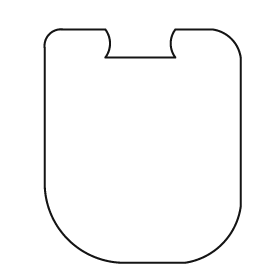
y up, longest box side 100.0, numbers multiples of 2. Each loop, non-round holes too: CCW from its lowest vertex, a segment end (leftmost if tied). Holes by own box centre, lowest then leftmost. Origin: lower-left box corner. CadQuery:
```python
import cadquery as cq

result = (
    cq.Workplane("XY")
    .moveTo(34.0, 0.0)
    .lineTo(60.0, 0.0)
    .threePointArc((76.0, 8.0), (84.0, 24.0))
    .lineTo(84.0, 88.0)
    .threePointArc((80.0, 96.0), (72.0, 100.0))
    .lineTo(56.0, 100.0)
    .threePointArc((54.0, 94.0), (56.0, 88.0))
    .lineTo(26.0, 88.0)
    .threePointArc((28.0, 94.0), (26.0, 100.0))
    .lineTo(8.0, 100.0)
    .threePointArc((2.0, 98.0), (0.0, 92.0))
    .lineTo(0.0, 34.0)
    .threePointArc((10.0, 10.0), (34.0, 0.0))
    .close()
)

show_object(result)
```